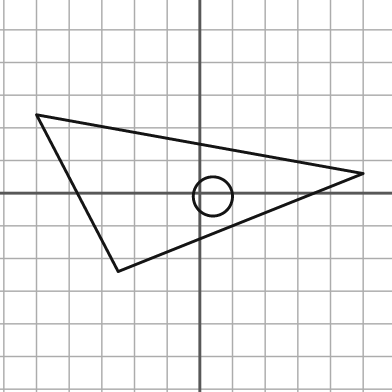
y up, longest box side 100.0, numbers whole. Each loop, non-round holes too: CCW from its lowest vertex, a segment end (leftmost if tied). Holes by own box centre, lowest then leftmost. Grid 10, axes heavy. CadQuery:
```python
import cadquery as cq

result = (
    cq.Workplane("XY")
    .moveTo(-25.0, -24.0)
    .lineTo(50.0, 6.0)
    .lineTo(-50.0, 24.0)
    .close()
    .moveTo(4.0, -1.0)
    .circle(6.0)
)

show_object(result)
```